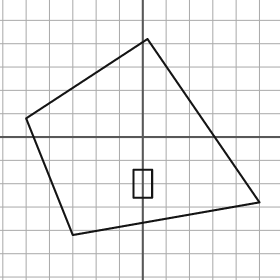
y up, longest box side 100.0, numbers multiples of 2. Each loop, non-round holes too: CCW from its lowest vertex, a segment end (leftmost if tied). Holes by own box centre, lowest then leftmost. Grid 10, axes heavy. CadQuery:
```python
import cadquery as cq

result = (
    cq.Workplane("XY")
    .moveTo(-30.0, -42.0)
    .lineTo(50.0, -28.0)
    .lineTo(2.0, 42.0)
    .lineTo(-50.0, 8.0)
    .close()
    .moveTo(-4.0, -26.0)
    .lineTo(4.0, -26.0)
    .lineTo(4.0, -14.0)
    .lineTo(-4.0, -14.0)
    .close()
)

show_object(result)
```